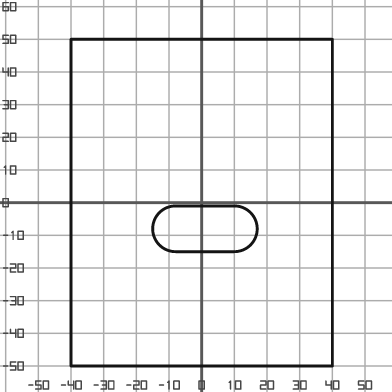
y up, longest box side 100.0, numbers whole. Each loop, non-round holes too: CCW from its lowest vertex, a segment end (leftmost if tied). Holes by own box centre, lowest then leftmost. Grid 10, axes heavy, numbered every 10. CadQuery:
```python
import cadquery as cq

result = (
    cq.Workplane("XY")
    .moveTo(-40.0, -50.0)
    .lineTo(40.0, -50.0)
    .lineTo(40.0, 50.0)
    .lineTo(-40.0, 50.0)
    .close()
    .moveTo(-8.0, -15.0)
    .lineTo(10.0, -15.0)
    .threePointArc((17.0, -8.0), (10.0, -1.0))
    .lineTo(-8.0, -1.0)
    .threePointArc((-15.0, -8.0), (-8.0, -15.0))
    .close()
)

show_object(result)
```